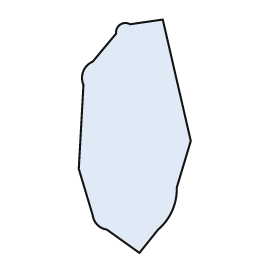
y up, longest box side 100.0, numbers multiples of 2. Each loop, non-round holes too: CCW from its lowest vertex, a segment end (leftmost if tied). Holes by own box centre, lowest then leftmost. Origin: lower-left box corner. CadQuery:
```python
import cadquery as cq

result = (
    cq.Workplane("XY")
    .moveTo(26.0, 0.0)
    .lineTo(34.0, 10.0)
    .threePointArc((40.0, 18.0), (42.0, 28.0))
    .lineTo(48.0, 48.0)
    .lineTo(36.0, 100.0)
    .lineTo(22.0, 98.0)
    .threePointArc((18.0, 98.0), (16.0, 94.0))
    .lineTo(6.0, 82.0)
    .threePointArc((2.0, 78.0), (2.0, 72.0))
    .lineTo(0.0, 36.0)
    .lineTo(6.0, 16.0)
    .threePointArc((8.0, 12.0), (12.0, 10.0))
    .close()
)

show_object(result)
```